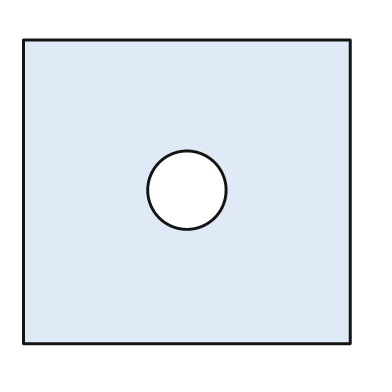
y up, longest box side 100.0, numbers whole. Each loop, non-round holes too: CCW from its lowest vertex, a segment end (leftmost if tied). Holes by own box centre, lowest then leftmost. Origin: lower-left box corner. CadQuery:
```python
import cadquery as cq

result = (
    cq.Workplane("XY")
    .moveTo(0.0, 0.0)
    .lineTo(100.0, 0.0)
    .lineTo(100.0, 93.0)
    .lineTo(0.0, 93.0)
    .close()
    .moveTo(50.0, 47.0)
    .circle(12.0)
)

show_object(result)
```